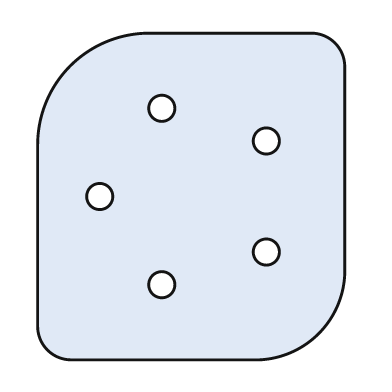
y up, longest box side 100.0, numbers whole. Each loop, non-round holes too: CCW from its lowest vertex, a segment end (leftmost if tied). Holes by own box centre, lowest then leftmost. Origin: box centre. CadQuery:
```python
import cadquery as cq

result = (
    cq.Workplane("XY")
    .moveTo(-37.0, -50.0)
    .lineTo(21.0, -50.0)
    .threePointArc((39.0, -42.0), (47.0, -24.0))
    .lineTo(47.0, 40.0)
    .threePointArc((44.0, 47.0), (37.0, 50.0))
    .lineTo(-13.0, 50.0)
    .threePointArc((-37.0, 40.0), (-47.0, 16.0))
    .lineTo(-47.0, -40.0)
    .threePointArc((-44.0, -47.0), (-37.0, -50.0))
    .close()
    .moveTo(-9.0, -27.0)
    .circle(4.0)
    .moveTo(23.0, -17.0)
    .circle(4.0)
    .moveTo(-28.0, 0.0)
    .circle(4.0)
    .moveTo(23.0, 17.0)
    .circle(4.0)
    .moveTo(-9.0, 27.0)
    .circle(4.0)
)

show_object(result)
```